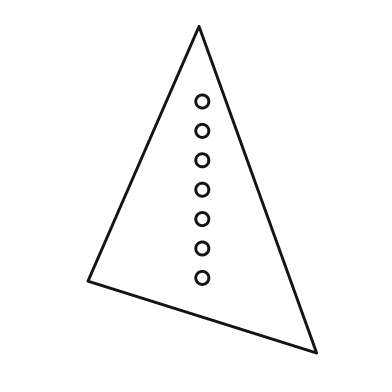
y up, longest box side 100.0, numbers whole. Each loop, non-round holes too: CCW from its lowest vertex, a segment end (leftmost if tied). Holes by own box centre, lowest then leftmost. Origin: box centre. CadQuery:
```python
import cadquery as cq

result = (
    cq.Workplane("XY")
    .moveTo(35.0, -50.0)
    .lineTo(-1.0, 50.0)
    .lineTo(-35.0, -28.0)
    .close()
    .moveTo(0.0, -27.0)
    .circle(2.0)
    .moveTo(0.0, -18.0)
    .circle(2.0)
    .moveTo(0.0, -9.0)
    .circle(2.0)
    .moveTo(0.0, 0.0)
    .circle(2.0)
    .moveTo(0.0, 9.0)
    .circle(2.0)
    .moveTo(0.0, 18.0)
    .circle(2.0)
    .moveTo(0.0, 27.0)
    .circle(2.0)
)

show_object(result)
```